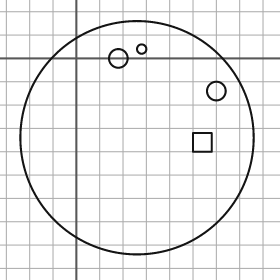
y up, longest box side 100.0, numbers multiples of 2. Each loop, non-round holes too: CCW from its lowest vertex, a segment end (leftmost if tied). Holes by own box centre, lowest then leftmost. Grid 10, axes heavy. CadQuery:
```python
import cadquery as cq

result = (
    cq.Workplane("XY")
    .moveTo(26.0, -34.0)
    .circle(50.0)
    .moveTo(50.0, -40.0)
    .lineTo(58.0, -40.0)
    .lineTo(58.0, -32.0)
    .lineTo(50.0, -32.0)
    .close()
    .moveTo(60.0, -14.0)
    .circle(4.0)
    .moveTo(18.0, 0.0)
    .circle(4.0)
    .moveTo(28.0, 4.0)
    .circle(2.0)
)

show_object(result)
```